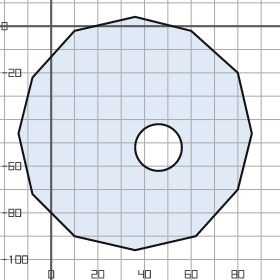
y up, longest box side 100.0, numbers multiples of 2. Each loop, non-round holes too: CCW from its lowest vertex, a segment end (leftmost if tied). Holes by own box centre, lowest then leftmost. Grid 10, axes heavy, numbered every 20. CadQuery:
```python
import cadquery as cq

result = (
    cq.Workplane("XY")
    .moveTo(36.0, -96.0)
    .lineTo(62.0, -90.0)
    .lineTo(80.0, -70.0)
    .lineTo(86.0, -46.0)
    .lineTo(80.0, -20.0)
    .lineTo(60.0, -2.0)
    .lineTo(36.0, 4.0)
    .lineTo(10.0, -2.0)
    .lineTo(-8.0, -22.0)
    .lineTo(-14.0, -46.0)
    .lineTo(-8.0, -72.0)
    .lineTo(10.0, -90.0)
    .close()
    .moveTo(46.0, -52.0)
    .circle(10.0)
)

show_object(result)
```